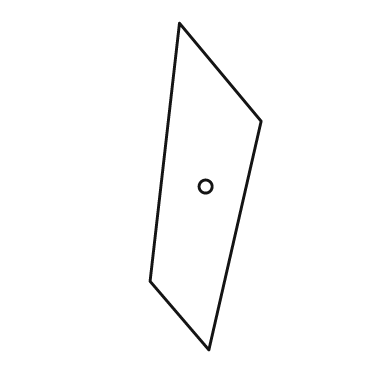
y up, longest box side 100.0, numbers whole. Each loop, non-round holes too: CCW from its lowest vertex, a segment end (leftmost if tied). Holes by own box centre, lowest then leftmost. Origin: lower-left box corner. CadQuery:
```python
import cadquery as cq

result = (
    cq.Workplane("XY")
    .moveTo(18.0, 0.0)
    .lineTo(34.0, 70.0)
    .lineTo(9.0, 100.0)
    .lineTo(0.0, 21.0)
    .close()
    .moveTo(17.0, 50.0)
    .circle(2.0)
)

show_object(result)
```